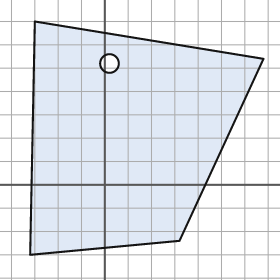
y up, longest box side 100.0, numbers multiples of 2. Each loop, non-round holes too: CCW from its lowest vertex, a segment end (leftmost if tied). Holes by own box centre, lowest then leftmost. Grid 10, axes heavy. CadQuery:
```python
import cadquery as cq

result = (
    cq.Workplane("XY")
    .moveTo(-32.0, -30.0)
    .lineTo(32.0, -24.0)
    .lineTo(68.0, 54.0)
    .lineTo(-30.0, 70.0)
    .close()
    .moveTo(2.0, 52.0)
    .circle(4.0)
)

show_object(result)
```